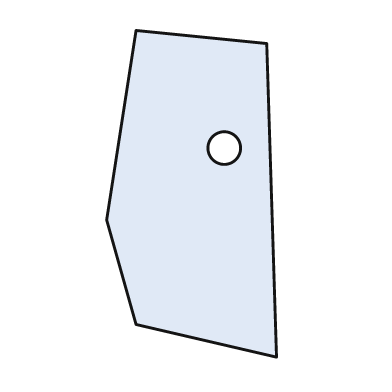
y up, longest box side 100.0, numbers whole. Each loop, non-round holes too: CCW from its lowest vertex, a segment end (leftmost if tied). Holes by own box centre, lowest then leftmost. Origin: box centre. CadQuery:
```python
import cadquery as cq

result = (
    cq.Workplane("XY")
    .moveTo(26.0, -50.0)
    .lineTo(23.0, 46.0)
    .lineTo(-17.0, 50.0)
    .lineTo(-26.0, -8.0)
    .lineTo(-17.0, -40.0)
    .close()
    .moveTo(10.0, 14.0)
    .circle(5.0)
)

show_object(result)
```